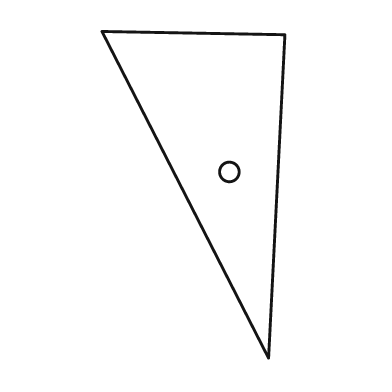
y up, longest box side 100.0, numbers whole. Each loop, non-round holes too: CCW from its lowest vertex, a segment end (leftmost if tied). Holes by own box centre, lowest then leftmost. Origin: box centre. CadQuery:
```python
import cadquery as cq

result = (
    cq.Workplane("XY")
    .moveTo(23.0, -50.0)
    .lineTo(28.0, 49.0)
    .lineTo(-28.0, 50.0)
    .close()
    .moveTo(11.0, 7.0)
    .circle(3.0)
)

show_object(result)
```